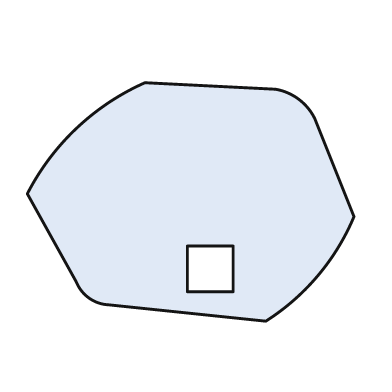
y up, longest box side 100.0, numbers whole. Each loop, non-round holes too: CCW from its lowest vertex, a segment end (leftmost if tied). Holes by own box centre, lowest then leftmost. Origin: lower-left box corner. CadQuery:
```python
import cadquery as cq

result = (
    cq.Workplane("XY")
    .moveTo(73.0, 0.0)
    .threePointArc((89.0, 14.0), (100.0, 32.0))
    .lineTo(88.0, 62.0)
    .threePointArc((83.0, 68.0), (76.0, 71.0))
    .lineTo(36.0, 73.0)
    .threePointArc((15.0, 59.0), (0.0, 39.0))
    .lineTo(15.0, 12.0)
    .threePointArc((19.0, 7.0), (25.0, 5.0))
    .close()
    .moveTo(49.0, 9.0)
    .lineTo(63.0, 9.0)
    .lineTo(63.0, 23.0)
    .lineTo(49.0, 23.0)
    .close()
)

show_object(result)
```